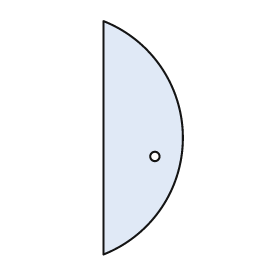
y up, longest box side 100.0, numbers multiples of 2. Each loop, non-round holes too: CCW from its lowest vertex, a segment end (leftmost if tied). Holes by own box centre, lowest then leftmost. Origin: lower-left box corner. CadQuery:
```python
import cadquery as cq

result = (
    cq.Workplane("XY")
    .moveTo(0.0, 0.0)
    .threePointArc((34.0, 50.0), (0.0, 100.0))
    .close()
    .moveTo(22.0, 42.0)
    .circle(2.0)
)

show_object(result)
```